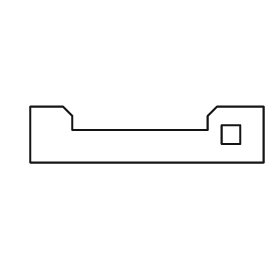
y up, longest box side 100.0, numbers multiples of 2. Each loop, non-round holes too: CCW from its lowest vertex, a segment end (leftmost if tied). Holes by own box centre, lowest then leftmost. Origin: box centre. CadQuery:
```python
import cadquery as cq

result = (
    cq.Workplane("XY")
    .moveTo(-50.0, -12.0)
    .lineTo(50.0, -12.0)
    .lineTo(50.0, 12.0)
    .lineTo(30.0, 12.0)
    .lineTo(26.0, 8.0)
    .lineTo(26.0, 2.0)
    .lineTo(-32.0, 2.0)
    .lineTo(-32.0, 8.0)
    .lineTo(-36.0, 12.0)
    .lineTo(-50.0, 12.0)
    .close()
    .moveTo(32.0, -4.0)
    .lineTo(40.0, -4.0)
    .lineTo(40.0, 4.0)
    .lineTo(32.0, 4.0)
    .close()
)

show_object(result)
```